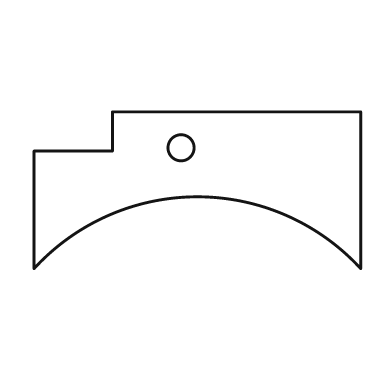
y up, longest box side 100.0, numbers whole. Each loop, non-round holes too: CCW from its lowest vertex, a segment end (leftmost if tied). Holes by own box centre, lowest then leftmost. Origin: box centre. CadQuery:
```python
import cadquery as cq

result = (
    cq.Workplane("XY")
    .moveTo(-50.0, -24.0)
    .threePointArc((0.0, -2.0), (50.0, -24.0))
    .lineTo(50.0, 24.0)
    .lineTo(-26.0, 24.0)
    .lineTo(-26.0, 12.0)
    .lineTo(-50.0, 12.0)
    .close()
    .moveTo(-5.0, 13.0)
    .circle(4.0)
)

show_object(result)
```